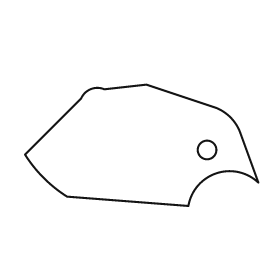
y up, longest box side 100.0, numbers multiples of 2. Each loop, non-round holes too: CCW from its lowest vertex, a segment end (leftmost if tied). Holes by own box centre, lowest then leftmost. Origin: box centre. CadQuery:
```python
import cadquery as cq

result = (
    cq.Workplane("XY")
    .moveTo(20.0, -26.0)
    .threePointArc((32.0, -12.0), (50.0, -16.0))
    .lineTo(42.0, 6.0)
    .threePointArc((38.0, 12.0), (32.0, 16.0))
    .lineTo(2.0, 26.0)
    .lineTo(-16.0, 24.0)
    .threePointArc((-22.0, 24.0), (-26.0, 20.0))
    .lineTo(-50.0, -4.0)
    .threePointArc((-42.0, -14.0), (-32.0, -22.0))
    .close()
    .moveTo(28.0, -2.0)
    .circle(4.0)
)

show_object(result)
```